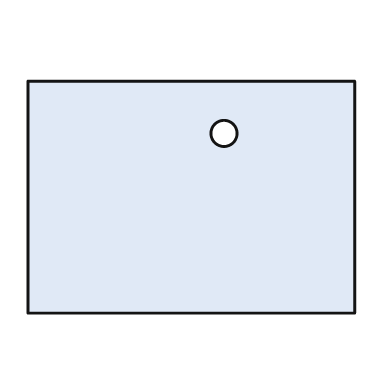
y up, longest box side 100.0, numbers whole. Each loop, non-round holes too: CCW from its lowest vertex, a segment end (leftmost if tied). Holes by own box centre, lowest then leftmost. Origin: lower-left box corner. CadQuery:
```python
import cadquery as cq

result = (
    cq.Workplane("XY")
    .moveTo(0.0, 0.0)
    .lineTo(100.0, 0.0)
    .lineTo(100.0, 71.0)
    .lineTo(0.0, 71.0)
    .close()
    .moveTo(60.0, 55.0)
    .circle(4.0)
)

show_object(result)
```